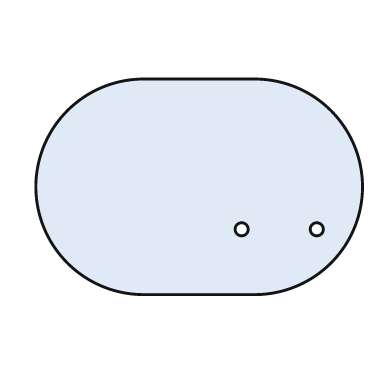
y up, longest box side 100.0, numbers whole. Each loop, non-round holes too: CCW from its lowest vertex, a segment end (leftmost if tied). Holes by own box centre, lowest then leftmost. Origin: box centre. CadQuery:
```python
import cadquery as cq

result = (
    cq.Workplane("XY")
    .moveTo(-17.0, -33.0)
    .lineTo(17.0, -33.0)
    .threePointArc((50.0, 0.0), (17.0, 33.0))
    .lineTo(-17.0, 33.0)
    .threePointArc((-50.0, 0.0), (-17.0, -33.0))
    .close()
    .moveTo(13.0, -13.0)
    .circle(2.0)
    .moveTo(36.0, -13.0)
    .circle(2.0)
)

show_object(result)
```